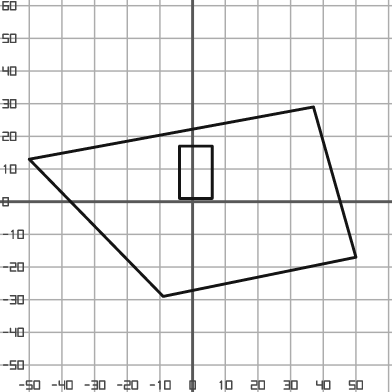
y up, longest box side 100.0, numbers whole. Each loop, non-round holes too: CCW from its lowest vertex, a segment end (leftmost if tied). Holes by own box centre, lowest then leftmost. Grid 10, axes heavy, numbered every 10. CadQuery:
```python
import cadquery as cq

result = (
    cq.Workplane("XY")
    .moveTo(-9.0, -29.0)
    .lineTo(50.0, -17.0)
    .lineTo(37.0, 29.0)
    .lineTo(-50.0, 13.0)
    .close()
    .moveTo(-4.0, 1.0)
    .lineTo(6.0, 1.0)
    .lineTo(6.0, 17.0)
    .lineTo(-4.0, 17.0)
    .close()
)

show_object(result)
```